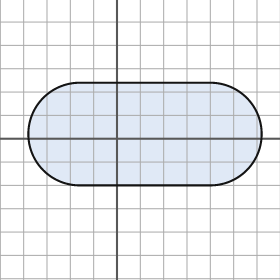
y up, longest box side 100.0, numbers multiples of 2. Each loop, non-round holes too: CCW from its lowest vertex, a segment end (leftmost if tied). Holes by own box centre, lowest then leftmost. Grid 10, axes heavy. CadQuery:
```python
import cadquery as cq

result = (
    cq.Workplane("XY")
    .moveTo(-16.0, -20.0)
    .lineTo(40.0, -20.0)
    .threePointArc((62.0, 2.0), (40.0, 24.0))
    .lineTo(-16.0, 24.0)
    .threePointArc((-38.0, 2.0), (-16.0, -20.0))
    .close()
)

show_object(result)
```